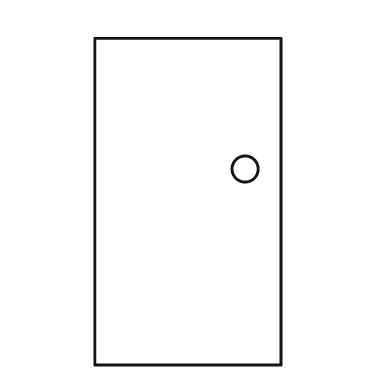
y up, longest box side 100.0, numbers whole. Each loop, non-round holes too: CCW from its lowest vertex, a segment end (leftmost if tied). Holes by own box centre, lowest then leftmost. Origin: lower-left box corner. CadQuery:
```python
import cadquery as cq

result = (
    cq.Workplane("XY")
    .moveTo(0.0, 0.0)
    .lineTo(57.0, 0.0)
    .lineTo(57.0, 100.0)
    .lineTo(0.0, 100.0)
    .close()
    .moveTo(46.0, 60.0)
    .circle(4.0)
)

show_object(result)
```